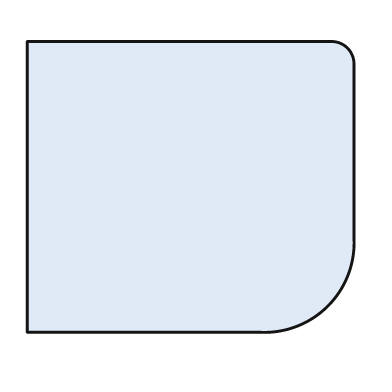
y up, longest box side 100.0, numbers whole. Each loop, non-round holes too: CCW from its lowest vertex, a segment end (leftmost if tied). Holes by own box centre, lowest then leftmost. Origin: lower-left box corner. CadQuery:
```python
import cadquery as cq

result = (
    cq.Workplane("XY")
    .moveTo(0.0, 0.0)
    .lineTo(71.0, 0.0)
    .threePointArc((92.0, 8.0), (100.0, 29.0))
    .lineTo(100.0, 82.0)
    .threePointArc((98.0, 87.0), (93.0, 89.0))
    .lineTo(0.0, 89.0)
    .close()
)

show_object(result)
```